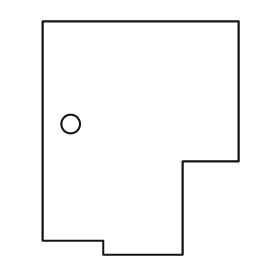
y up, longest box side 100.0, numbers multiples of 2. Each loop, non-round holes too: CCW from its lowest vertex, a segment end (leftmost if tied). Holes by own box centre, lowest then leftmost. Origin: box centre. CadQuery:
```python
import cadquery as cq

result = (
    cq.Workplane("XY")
    .moveTo(-16.0, -50.0)
    .lineTo(18.0, -50.0)
    .lineTo(18.0, -10.0)
    .lineTo(42.0, -10.0)
    .lineTo(42.0, 50.0)
    .lineTo(-42.0, 50.0)
    .lineTo(-42.0, -44.0)
    .lineTo(-16.0, -44.0)
    .close()
    .moveTo(-30.0, 6.0)
    .circle(4.0)
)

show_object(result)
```